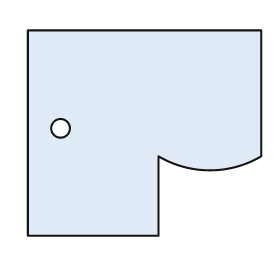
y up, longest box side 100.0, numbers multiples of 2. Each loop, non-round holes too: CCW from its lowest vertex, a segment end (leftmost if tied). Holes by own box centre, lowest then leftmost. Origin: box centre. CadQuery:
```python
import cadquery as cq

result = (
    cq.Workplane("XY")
    .moveTo(-50.0, -44.0)
    .lineTo(6.0, -44.0)
    .lineTo(6.0, -10.0)
    .threePointArc((28.0, -16.0), (50.0, -10.0))
    .lineTo(50.0, 44.0)
    .lineTo(-50.0, 44.0)
    .close()
    .moveTo(-36.0, 2.0)
    .circle(4.0)
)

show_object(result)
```